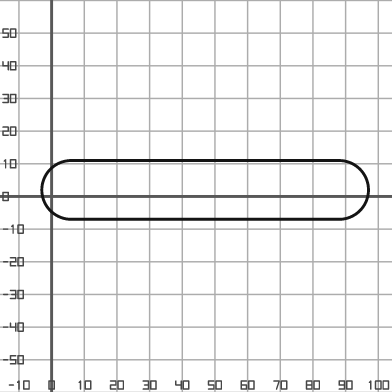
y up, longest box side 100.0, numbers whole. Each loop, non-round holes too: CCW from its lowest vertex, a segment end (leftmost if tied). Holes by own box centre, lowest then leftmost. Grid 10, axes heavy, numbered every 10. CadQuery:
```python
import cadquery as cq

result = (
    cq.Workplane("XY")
    .moveTo(6.0, -7.0)
    .lineTo(88.0, -7.0)
    .threePointArc((97.0, 2.0), (88.0, 11.0))
    .lineTo(6.0, 11.0)
    .threePointArc((-3.0, 2.0), (6.0, -7.0))
    .close()
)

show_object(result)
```